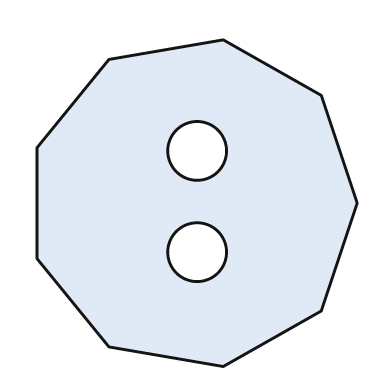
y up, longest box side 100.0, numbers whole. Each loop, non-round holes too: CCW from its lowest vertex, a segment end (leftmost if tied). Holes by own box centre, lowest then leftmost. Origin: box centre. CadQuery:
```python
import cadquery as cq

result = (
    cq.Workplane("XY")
    .moveTo(8.0, -50.0)
    .lineTo(38.0, -33.0)
    .lineTo(49.0, 0.0)
    .lineTo(38.0, 33.0)
    .lineTo(8.0, 50.0)
    .lineTo(-27.0, 44.0)
    .lineTo(-49.0, 17.0)
    .lineTo(-49.0, -17.0)
    .lineTo(-27.0, -44.0)
    .close()
    .moveTo(0.0, -15.0)
    .circle(9.0)
    .moveTo(0.0, 16.0)
    .circle(9.0)
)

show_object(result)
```